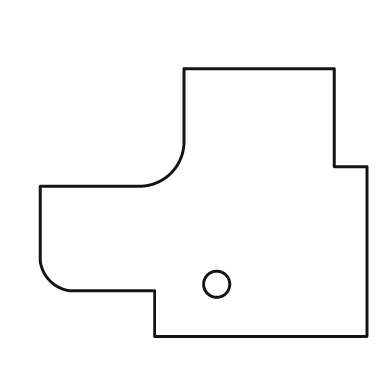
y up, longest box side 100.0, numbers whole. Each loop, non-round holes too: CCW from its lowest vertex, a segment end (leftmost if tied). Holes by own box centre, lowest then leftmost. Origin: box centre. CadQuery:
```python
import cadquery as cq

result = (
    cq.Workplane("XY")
    .moveTo(-15.0, -41.0)
    .lineTo(50.0, -41.0)
    .lineTo(50.0, 11.0)
    .lineTo(40.0, 11.0)
    .lineTo(40.0, 41.0)
    .lineTo(-6.0, 41.0)
    .lineTo(-6.0, 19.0)
    .threePointArc((-10.0, 9.0), (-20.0, 5.0))
    .lineTo(-50.0, 5.0)
    .lineTo(-50.0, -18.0)
    .threePointArc((-47.0, -24.0), (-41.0, -27.0))
    .lineTo(-15.0, -27.0)
    .close()
    .moveTo(4.0, -25.0)
    .circle(4.0)
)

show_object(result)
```